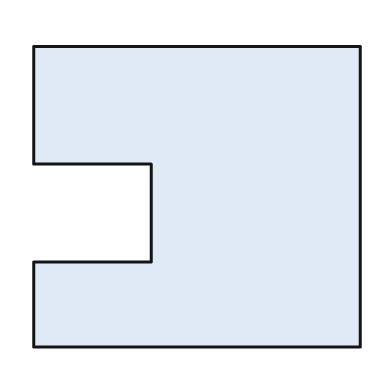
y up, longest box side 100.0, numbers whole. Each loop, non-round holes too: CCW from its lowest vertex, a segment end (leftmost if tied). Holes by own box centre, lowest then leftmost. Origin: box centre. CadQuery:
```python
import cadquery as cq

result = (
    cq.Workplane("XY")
    .moveTo(-50.0, -46.0)
    .lineTo(50.0, -46.0)
    .lineTo(50.0, 46.0)
    .lineTo(-50.0, 46.0)
    .lineTo(-50.0, 10.0)
    .lineTo(-14.0, 10.0)
    .lineTo(-14.0, -20.0)
    .lineTo(-50.0, -20.0)
    .close()
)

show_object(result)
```